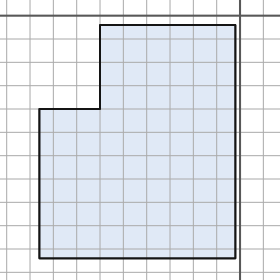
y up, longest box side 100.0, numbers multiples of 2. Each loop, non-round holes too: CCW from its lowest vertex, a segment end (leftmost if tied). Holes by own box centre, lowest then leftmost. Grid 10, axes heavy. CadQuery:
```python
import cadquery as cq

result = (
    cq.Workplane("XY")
    .moveTo(-86.0, -104.0)
    .lineTo(-2.0, -104.0)
    .lineTo(-2.0, -4.0)
    .lineTo(-60.0, -4.0)
    .lineTo(-60.0, -40.0)
    .lineTo(-86.0, -40.0)
    .close()
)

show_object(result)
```